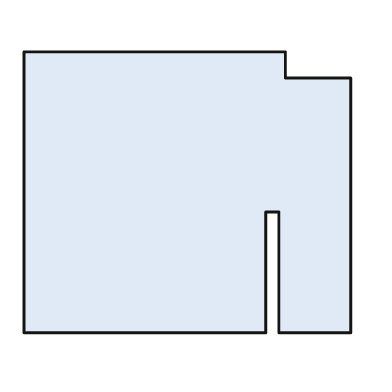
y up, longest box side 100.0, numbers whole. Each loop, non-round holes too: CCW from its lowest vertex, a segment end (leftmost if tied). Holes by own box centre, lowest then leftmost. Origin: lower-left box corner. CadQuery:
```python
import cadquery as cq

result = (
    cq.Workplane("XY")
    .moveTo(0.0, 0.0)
    .lineTo(74.0, 0.0)
    .lineTo(74.0, 37.0)
    .lineTo(78.0, 37.0)
    .lineTo(78.0, 0.0)
    .lineTo(100.0, 0.0)
    .lineTo(100.0, 78.0)
    .lineTo(80.0, 78.0)
    .lineTo(80.0, 86.0)
    .lineTo(0.0, 86.0)
    .close()
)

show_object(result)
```